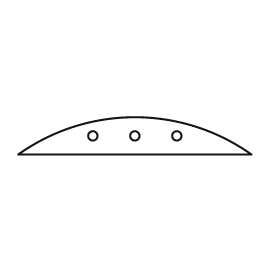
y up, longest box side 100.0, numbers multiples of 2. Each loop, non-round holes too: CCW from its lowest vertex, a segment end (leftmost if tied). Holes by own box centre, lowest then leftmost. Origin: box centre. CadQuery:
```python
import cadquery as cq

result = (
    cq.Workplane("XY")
    .moveTo(-50.0, -8.0)
    .lineTo(50.0, -8.0)
    .threePointArc((0.0, 8.0), (-50.0, -8.0))
    .close()
    .moveTo(-18.0, 0.0)
    .circle(2.0)
    .moveTo(0.0, 0.0)
    .circle(2.0)
    .moveTo(18.0, 0.0)
    .circle(2.0)
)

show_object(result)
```